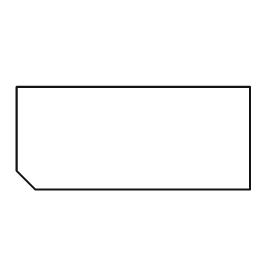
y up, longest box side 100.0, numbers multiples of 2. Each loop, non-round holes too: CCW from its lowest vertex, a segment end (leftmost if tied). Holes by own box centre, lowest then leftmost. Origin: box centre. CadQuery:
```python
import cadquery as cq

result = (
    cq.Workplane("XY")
    .moveTo(-42.0, -22.0)
    .lineTo(50.0, -22.0)
    .lineTo(50.0, 22.0)
    .lineTo(-50.0, 22.0)
    .lineTo(-50.0, -14.0)
    .close()
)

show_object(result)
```